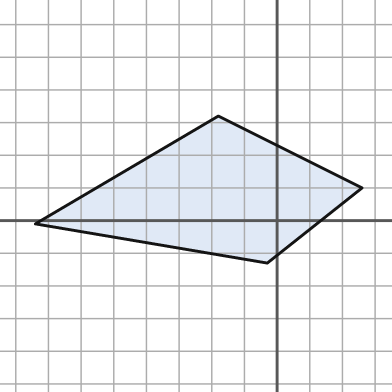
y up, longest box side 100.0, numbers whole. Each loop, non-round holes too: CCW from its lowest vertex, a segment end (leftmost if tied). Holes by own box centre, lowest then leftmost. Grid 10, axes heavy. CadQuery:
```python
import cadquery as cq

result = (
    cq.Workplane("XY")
    .moveTo(-3.0, -13.0)
    .lineTo(26.0, 10.0)
    .lineTo(-18.0, 32.0)
    .lineTo(-74.0, -1.0)
    .close()
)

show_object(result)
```